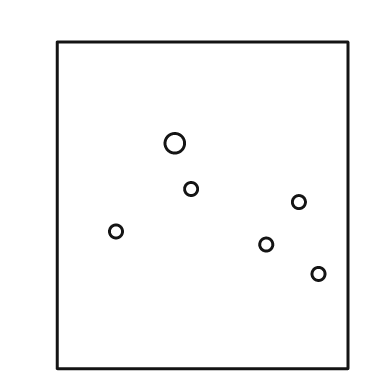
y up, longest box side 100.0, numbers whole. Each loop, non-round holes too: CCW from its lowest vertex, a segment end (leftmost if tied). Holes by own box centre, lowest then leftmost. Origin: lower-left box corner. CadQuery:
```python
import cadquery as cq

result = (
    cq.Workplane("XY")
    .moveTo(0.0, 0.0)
    .lineTo(89.0, 0.0)
    .lineTo(89.0, 100.0)
    .lineTo(0.0, 100.0)
    .close()
    .moveTo(80.0, 29.0)
    .circle(2.0)
    .moveTo(64.0, 38.0)
    .circle(2.0)
    .moveTo(18.0, 42.0)
    .circle(2.0)
    .moveTo(74.0, 51.0)
    .circle(2.0)
    .moveTo(41.0, 55.0)
    .circle(2.0)
    .moveTo(36.0, 69.0)
    .circle(3.0)
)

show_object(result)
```